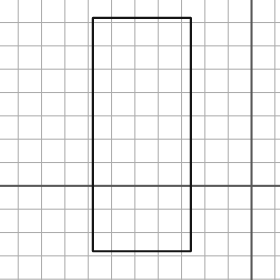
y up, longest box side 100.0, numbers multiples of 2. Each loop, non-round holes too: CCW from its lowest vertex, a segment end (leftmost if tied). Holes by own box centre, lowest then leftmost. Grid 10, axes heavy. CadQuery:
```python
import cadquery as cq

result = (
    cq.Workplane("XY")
    .moveTo(-68.0, -28.0)
    .lineTo(-26.0, -28.0)
    .lineTo(-26.0, 72.0)
    .lineTo(-68.0, 72.0)
    .close()
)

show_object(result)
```